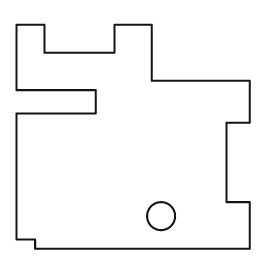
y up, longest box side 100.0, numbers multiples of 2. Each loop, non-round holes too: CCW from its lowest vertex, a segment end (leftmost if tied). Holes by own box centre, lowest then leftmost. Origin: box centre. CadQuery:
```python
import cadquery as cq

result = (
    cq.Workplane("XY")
    .moveTo(-42.0, -48.0)
    .lineTo(50.0, -48.0)
    .lineTo(50.0, -28.0)
    .lineTo(40.0, -28.0)
    .lineTo(40.0, 6.0)
    .lineTo(50.0, 6.0)
    .lineTo(50.0, 24.0)
    .lineTo(8.0, 24.0)
    .lineTo(8.0, 48.0)
    .lineTo(-8.0, 48.0)
    .lineTo(-8.0, 36.0)
    .lineTo(-38.0, 36.0)
    .lineTo(-38.0, 48.0)
    .lineTo(-50.0, 48.0)
    .lineTo(-50.0, 20.0)
    .lineTo(-16.0, 20.0)
    .lineTo(-16.0, 10.0)
    .lineTo(-50.0, 10.0)
    .lineTo(-50.0, -44.0)
    .lineTo(-42.0, -44.0)
    .close()
    .moveTo(12.0, -34.0)
    .circle(6.0)
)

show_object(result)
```